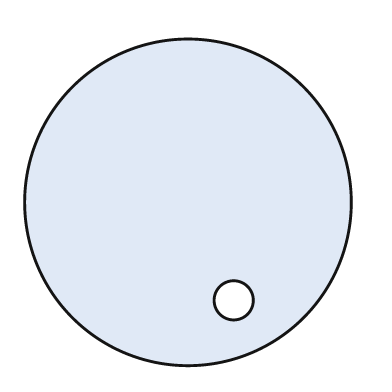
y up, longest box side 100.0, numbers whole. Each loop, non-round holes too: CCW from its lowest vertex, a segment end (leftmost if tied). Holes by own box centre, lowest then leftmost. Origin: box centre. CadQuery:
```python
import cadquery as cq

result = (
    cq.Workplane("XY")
    .moveTo(0.0, 0.0)
    .circle(50.0)
    .moveTo(14.0, -30.0)
    .circle(6.0)
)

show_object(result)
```